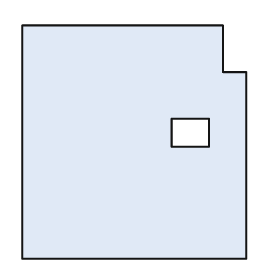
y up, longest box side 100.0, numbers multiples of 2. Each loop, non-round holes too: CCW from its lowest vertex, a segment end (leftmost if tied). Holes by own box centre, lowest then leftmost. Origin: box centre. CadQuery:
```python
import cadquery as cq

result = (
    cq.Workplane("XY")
    .moveTo(-48.0, -50.0)
    .lineTo(48.0, -50.0)
    .lineTo(48.0, 30.0)
    .lineTo(38.0, 30.0)
    .lineTo(38.0, 50.0)
    .lineTo(-48.0, 50.0)
    .close()
    .moveTo(16.0, -2.0)
    .lineTo(32.0, -2.0)
    .lineTo(32.0, 10.0)
    .lineTo(16.0, 10.0)
    .close()
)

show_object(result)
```